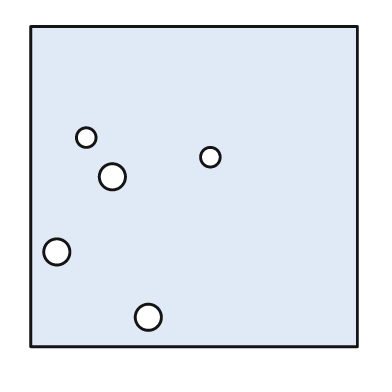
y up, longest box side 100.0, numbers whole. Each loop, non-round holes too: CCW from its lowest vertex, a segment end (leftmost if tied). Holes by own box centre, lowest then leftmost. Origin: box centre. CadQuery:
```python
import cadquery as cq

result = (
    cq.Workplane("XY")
    .moveTo(-50.0, -49.0)
    .lineTo(50.0, -49.0)
    .lineTo(50.0, 49.0)
    .lineTo(-50.0, 49.0)
    .close()
    .moveTo(-14.0, -40.0)
    .circle(4.0)
    .moveTo(-42.0, -20.0)
    .circle(4.0)
    .moveTo(-25.0, 3.0)
    .circle(4.0)
    .moveTo(5.0, 9.0)
    .circle(3.0)
    .moveTo(-33.0, 15.0)
    .circle(3.0)
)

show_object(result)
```